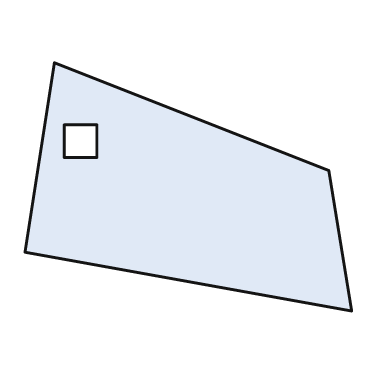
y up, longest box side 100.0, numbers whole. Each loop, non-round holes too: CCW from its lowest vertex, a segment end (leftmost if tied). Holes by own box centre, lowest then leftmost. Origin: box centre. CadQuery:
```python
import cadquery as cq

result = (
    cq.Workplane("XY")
    .moveTo(50.0, -38.0)
    .lineTo(43.0, 5.0)
    .lineTo(-41.0, 38.0)
    .lineTo(-50.0, -20.0)
    .close()
    .moveTo(-38.0, 9.0)
    .lineTo(-28.0, 9.0)
    .lineTo(-28.0, 19.0)
    .lineTo(-38.0, 19.0)
    .close()
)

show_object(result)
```